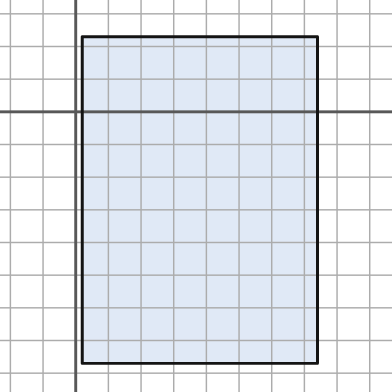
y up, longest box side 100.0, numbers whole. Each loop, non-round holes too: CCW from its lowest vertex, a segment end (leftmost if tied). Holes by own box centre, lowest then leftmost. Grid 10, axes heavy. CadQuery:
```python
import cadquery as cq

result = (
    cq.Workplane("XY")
    .moveTo(2.0, -77.0)
    .lineTo(74.0, -77.0)
    .lineTo(74.0, 23.0)
    .lineTo(2.0, 23.0)
    .close()
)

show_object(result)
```